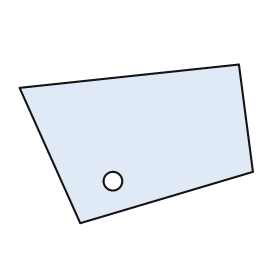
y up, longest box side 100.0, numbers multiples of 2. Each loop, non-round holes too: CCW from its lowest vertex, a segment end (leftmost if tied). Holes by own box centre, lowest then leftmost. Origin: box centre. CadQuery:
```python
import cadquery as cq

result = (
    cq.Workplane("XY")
    .moveTo(-24.0, -34.0)
    .lineTo(50.0, -12.0)
    .lineTo(44.0, 34.0)
    .lineTo(-50.0, 24.0)
    .close()
    .moveTo(-10.0, -16.0)
    .circle(4.0)
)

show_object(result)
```